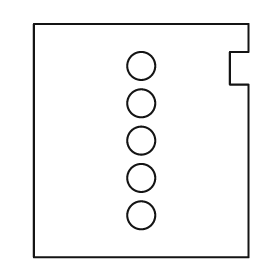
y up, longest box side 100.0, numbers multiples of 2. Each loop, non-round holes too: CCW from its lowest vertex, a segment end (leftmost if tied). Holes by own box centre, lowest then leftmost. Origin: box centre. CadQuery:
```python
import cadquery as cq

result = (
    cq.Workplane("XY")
    .moveTo(-46.0, -50.0)
    .lineTo(46.0, -50.0)
    .lineTo(46.0, 24.0)
    .lineTo(38.0, 24.0)
    .lineTo(38.0, 38.0)
    .lineTo(46.0, 38.0)
    .lineTo(46.0, 50.0)
    .lineTo(-46.0, 50.0)
    .close()
    .moveTo(0.0, -32.0)
    .circle(6.0)
    .moveTo(0.0, -16.0)
    .circle(6.0)
    .moveTo(0.0, 0.0)
    .circle(6.0)
    .moveTo(0.0, 16.0)
    .circle(6.0)
    .moveTo(0.0, 32.0)
    .circle(6.0)
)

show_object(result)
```